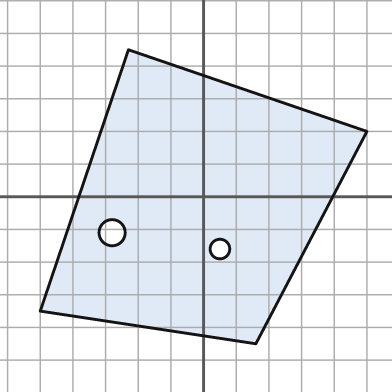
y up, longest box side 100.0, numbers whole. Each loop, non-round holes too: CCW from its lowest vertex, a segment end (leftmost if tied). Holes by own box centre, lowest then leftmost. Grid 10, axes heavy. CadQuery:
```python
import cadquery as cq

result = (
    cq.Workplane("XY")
    .moveTo(16.0, -45.0)
    .lineTo(50.0, 20.0)
    .lineTo(-23.0, 45.0)
    .lineTo(-50.0, -35.0)
    .close()
    .moveTo(5.0, -16.0)
    .circle(3.0)
    .moveTo(-28.0, -11.0)
    .circle(4.0)
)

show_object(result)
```